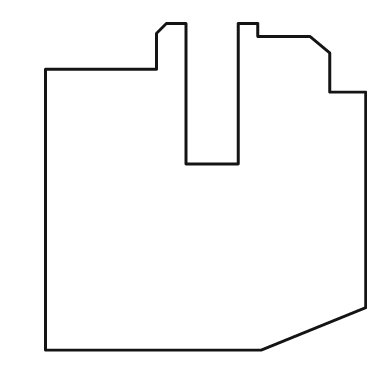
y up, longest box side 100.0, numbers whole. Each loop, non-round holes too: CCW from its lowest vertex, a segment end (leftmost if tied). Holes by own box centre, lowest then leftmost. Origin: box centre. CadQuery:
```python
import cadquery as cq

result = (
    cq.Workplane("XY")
    .moveTo(-49.0, -50.0)
    .lineTo(17.0, -50.0)
    .lineTo(49.0, -37.0)
    .lineTo(49.0, 29.0)
    .lineTo(38.0, 29.0)
    .lineTo(38.0, 41.0)
    .lineTo(32.0, 46.0)
    .lineTo(16.0, 46.0)
    .lineTo(16.0, 50.0)
    .lineTo(10.0, 50.0)
    .lineTo(10.0, 7.0)
    .lineTo(-6.0, 7.0)
    .lineTo(-6.0, 50.0)
    .lineTo(-12.0, 50.0)
    .lineTo(-15.0, 47.0)
    .lineTo(-15.0, 36.0)
    .lineTo(-49.0, 36.0)
    .close()
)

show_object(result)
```